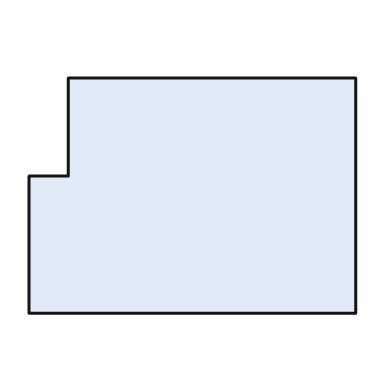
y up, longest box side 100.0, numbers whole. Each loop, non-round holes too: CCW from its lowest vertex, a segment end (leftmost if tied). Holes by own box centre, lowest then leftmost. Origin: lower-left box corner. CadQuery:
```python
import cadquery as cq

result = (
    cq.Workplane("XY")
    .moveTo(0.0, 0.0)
    .lineTo(100.0, 0.0)
    .lineTo(100.0, 72.0)
    .lineTo(12.0, 72.0)
    .lineTo(12.0, 42.0)
    .lineTo(0.0, 42.0)
    .close()
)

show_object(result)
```